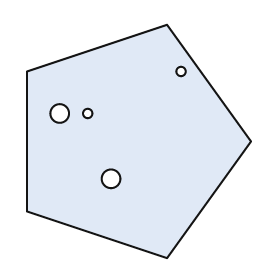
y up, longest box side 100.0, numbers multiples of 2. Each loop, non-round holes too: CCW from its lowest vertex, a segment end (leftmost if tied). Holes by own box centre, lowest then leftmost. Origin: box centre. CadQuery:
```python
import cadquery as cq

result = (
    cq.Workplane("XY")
    .moveTo(12.0, -50.0)
    .lineTo(48.0, 0.0)
    .lineTo(12.0, 50.0)
    .lineTo(-48.0, 30.0)
    .lineTo(-48.0, -30.0)
    .close()
    .moveTo(-12.0, -16.0)
    .circle(4.0)
    .moveTo(-34.0, 12.0)
    .circle(4.0)
    .moveTo(-22.0, 12.0)
    .circle(2.0)
    .moveTo(18.0, 30.0)
    .circle(2.0)
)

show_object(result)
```